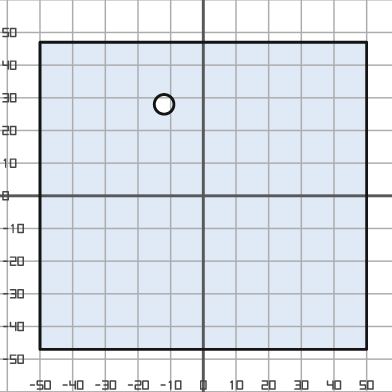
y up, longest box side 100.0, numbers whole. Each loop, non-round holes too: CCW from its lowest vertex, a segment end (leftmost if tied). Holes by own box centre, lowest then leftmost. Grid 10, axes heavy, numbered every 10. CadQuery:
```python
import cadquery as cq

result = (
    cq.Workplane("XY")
    .moveTo(-50.0, -47.0)
    .lineTo(50.0, -47.0)
    .lineTo(50.0, 47.0)
    .lineTo(-50.0, 47.0)
    .close()
    .moveTo(-12.0, 28.0)
    .circle(3.0)
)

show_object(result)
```